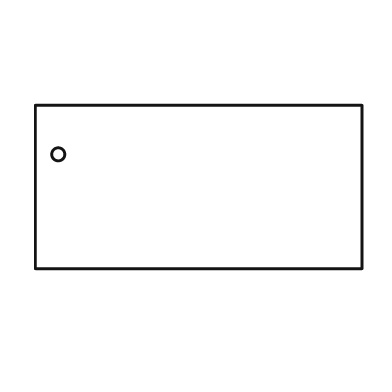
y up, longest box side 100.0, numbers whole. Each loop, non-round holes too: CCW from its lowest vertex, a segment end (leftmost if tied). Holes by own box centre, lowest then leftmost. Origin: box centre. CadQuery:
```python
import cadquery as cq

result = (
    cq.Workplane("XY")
    .moveTo(-50.0, -25.0)
    .lineTo(50.0, -25.0)
    .lineTo(50.0, 25.0)
    .lineTo(-50.0, 25.0)
    .close()
    .moveTo(-43.0, 10.0)
    .circle(2.0)
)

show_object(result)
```